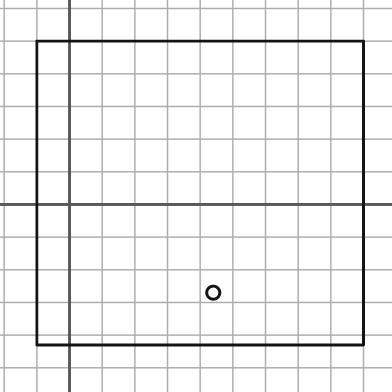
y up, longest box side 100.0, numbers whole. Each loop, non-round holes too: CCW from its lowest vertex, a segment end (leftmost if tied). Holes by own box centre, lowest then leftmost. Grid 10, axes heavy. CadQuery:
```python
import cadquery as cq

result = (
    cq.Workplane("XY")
    .moveTo(-10.0, -43.0)
    .lineTo(90.0, -43.0)
    .lineTo(90.0, 50.0)
    .lineTo(-10.0, 50.0)
    .close()
    .moveTo(44.0, -27.0)
    .circle(2.0)
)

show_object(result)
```